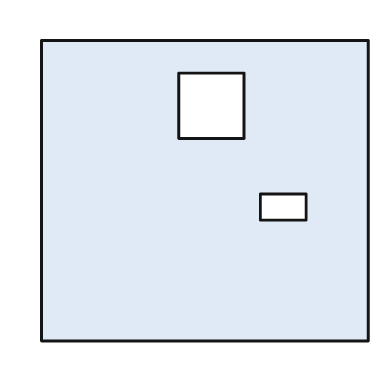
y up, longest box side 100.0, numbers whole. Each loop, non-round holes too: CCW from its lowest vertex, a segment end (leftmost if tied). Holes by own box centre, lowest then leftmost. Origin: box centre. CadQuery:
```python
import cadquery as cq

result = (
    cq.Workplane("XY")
    .moveTo(-50.0, -46.0)
    .lineTo(50.0, -46.0)
    .lineTo(50.0, 46.0)
    .lineTo(-50.0, 46.0)
    .close()
    .moveTo(17.0, -9.0)
    .lineTo(31.0, -9.0)
    .lineTo(31.0, -1.0)
    .lineTo(17.0, -1.0)
    .close()
    .moveTo(-8.0, 16.0)
    .lineTo(12.0, 16.0)
    .lineTo(12.0, 36.0)
    .lineTo(-8.0, 36.0)
    .close()
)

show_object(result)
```